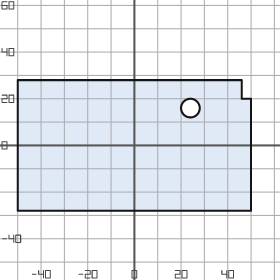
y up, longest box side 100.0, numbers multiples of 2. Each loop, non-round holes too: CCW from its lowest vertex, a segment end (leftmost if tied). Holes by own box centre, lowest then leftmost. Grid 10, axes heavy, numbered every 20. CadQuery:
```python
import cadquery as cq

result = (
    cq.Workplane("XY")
    .moveTo(-50.0, -28.0)
    .lineTo(50.0, -28.0)
    .lineTo(50.0, 20.0)
    .lineTo(46.0, 20.0)
    .lineTo(46.0, 28.0)
    .lineTo(-50.0, 28.0)
    .close()
    .moveTo(24.0, 16.0)
    .circle(4.0)
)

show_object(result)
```